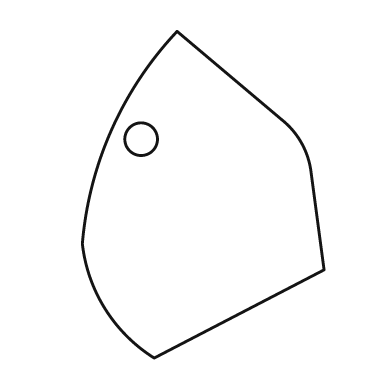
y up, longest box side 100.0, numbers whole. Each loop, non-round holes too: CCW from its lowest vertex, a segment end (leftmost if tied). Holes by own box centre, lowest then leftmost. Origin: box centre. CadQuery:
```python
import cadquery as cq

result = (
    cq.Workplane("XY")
    .moveTo(-15.0, -50.0)
    .lineTo(37.0, -23.0)
    .lineTo(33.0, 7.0)
    .threePointArc((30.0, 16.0), (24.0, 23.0))
    .lineTo(-8.0, 50.0)
    .threePointArc((-28.0, 20.0), (-37.0, -15.0))
    .threePointArc((-30.0, -35.0), (-15.0, -50.0))
    .close()
    .moveTo(-19.0, 17.0)
    .circle(5.0)
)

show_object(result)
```